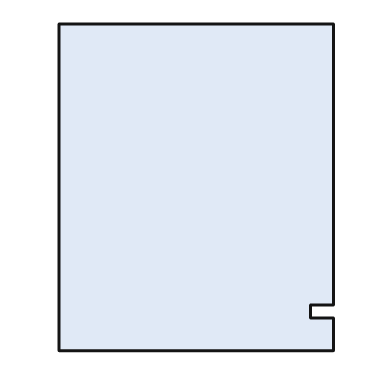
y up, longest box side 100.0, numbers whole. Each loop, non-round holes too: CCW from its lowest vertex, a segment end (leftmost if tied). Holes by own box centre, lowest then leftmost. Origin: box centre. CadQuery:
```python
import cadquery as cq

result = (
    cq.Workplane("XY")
    .moveTo(-42.0, -50.0)
    .lineTo(42.0, -50.0)
    .lineTo(42.0, -40.0)
    .lineTo(35.0, -40.0)
    .lineTo(35.0, -36.0)
    .lineTo(42.0, -36.0)
    .lineTo(42.0, 50.0)
    .lineTo(-42.0, 50.0)
    .close()
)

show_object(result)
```